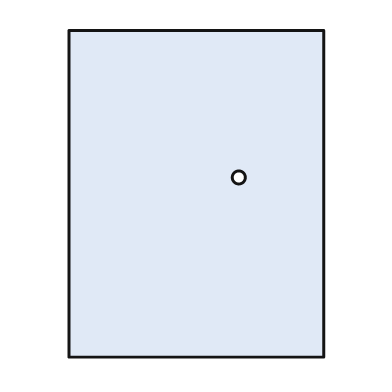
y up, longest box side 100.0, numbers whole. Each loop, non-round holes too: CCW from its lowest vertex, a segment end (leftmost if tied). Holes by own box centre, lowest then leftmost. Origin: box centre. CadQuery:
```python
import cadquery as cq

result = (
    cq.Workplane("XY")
    .moveTo(-39.0, -50.0)
    .lineTo(39.0, -50.0)
    .lineTo(39.0, 50.0)
    .lineTo(-39.0, 50.0)
    .close()
    .moveTo(13.0, 5.0)
    .circle(2.0)
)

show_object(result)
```